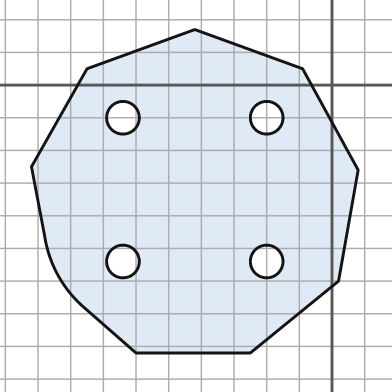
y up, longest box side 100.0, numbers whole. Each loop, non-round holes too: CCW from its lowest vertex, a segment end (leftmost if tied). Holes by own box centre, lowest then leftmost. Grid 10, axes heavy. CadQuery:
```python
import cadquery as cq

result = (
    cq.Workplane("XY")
    .moveTo(-60.0, -82.0)
    .lineTo(-25.0, -82.0)
    .lineTo(2.0, -60.0)
    .lineTo(8.0, -26.0)
    .lineTo(-9.0, 5.0)
    .lineTo(-42.0, 17.0)
    .lineTo(-75.0, 5.0)
    .lineTo(-92.0, -25.0)
    .lineTo(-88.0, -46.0)
    .threePointArc((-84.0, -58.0), (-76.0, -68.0))
    .close()
    .moveTo(-64.0, -54.0)
    .circle(5.0)
    .moveTo(-20.0, -54.0)
    .circle(5.0)
    .moveTo(-64.0, -10.0)
    .circle(5.0)
    .moveTo(-20.0, -10.0)
    .circle(5.0)
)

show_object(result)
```